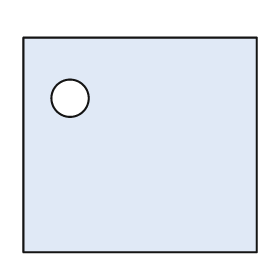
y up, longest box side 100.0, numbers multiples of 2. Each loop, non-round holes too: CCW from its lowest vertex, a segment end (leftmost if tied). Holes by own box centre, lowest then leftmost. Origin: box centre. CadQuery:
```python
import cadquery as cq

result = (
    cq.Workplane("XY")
    .moveTo(-50.0, -46.0)
    .lineTo(50.0, -46.0)
    .lineTo(50.0, 46.0)
    .lineTo(-50.0, 46.0)
    .close()
    .moveTo(-30.0, 20.0)
    .circle(8.0)
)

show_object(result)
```